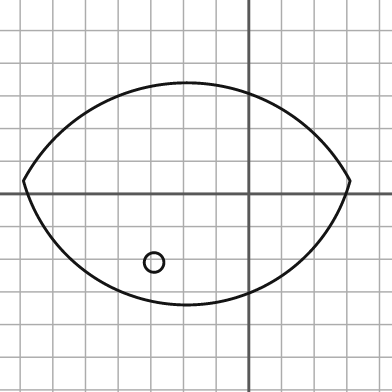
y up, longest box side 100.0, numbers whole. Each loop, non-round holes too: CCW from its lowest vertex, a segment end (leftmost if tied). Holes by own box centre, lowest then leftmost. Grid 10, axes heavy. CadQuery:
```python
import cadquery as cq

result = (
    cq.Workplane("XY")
    .moveTo(-69.0, 4.0)
    .threePointArc((-19.0, -34.0), (31.0, 4.0))
    .threePointArc((-19.0, 34.0), (-69.0, 4.0))
    .close()
    .moveTo(-29.0, -21.0)
    .circle(3.0)
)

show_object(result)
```